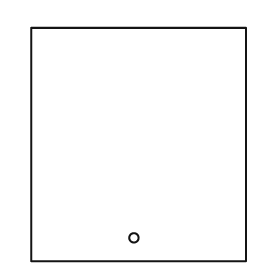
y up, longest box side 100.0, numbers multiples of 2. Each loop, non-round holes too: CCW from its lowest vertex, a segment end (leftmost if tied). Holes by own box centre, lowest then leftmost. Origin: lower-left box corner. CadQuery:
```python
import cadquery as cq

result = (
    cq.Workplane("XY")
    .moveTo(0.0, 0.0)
    .lineTo(92.0, 0.0)
    .lineTo(92.0, 100.0)
    .lineTo(0.0, 100.0)
    .close()
    .moveTo(44.0, 10.0)
    .circle(2.0)
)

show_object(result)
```